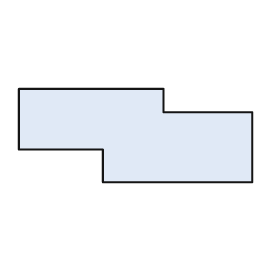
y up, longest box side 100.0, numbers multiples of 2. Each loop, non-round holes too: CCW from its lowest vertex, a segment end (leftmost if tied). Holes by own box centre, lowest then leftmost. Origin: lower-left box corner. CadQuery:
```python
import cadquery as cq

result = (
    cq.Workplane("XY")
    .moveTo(36.0, 0.0)
    .lineTo(100.0, 0.0)
    .lineTo(100.0, 30.0)
    .lineTo(62.0, 30.0)
    .lineTo(62.0, 40.0)
    .lineTo(0.0, 40.0)
    .lineTo(0.0, 14.0)
    .lineTo(36.0, 14.0)
    .close()
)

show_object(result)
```